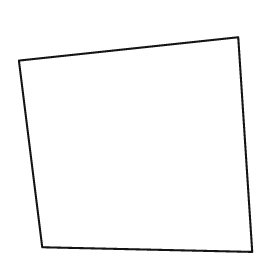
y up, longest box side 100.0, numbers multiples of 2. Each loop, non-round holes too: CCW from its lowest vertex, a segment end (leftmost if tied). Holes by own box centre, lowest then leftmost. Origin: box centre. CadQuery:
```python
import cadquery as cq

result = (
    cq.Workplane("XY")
    .moveTo(50.0, -46.0)
    .lineTo(44.0, 46.0)
    .lineTo(-50.0, 36.0)
    .lineTo(-40.0, -44.0)
    .close()
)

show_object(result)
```